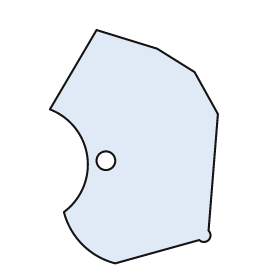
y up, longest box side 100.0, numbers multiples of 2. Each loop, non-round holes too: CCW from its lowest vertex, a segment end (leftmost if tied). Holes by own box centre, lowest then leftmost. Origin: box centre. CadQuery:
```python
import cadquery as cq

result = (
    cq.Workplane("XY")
    .moveTo(-8.0, -50.0)
    .lineTo(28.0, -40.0)
    .threePointArc((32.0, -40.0), (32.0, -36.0))
    .lineTo(36.0, 14.0)
    .lineTo(26.0, 32.0)
    .lineTo(10.0, 42.0)
    .lineTo(-16.0, 50.0)
    .lineTo(-36.0, 16.0)
    .threePointArc((-20.0, -4.0), (-30.0, -28.0))
    .threePointArc((-22.0, -42.0), (-8.0, -50.0))
    .close()
    .moveTo(-12.0, -6.0)
    .circle(4.0)
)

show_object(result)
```